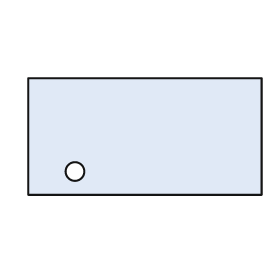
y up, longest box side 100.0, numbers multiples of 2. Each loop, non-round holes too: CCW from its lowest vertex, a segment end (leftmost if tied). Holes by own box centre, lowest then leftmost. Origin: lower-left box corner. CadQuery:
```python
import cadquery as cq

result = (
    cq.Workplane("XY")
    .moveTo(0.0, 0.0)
    .lineTo(100.0, 0.0)
    .lineTo(100.0, 50.0)
    .lineTo(0.0, 50.0)
    .close()
    .moveTo(20.0, 10.0)
    .circle(4.0)
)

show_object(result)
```